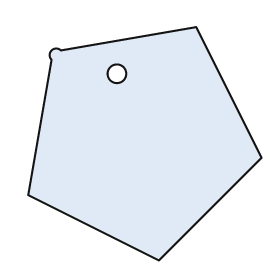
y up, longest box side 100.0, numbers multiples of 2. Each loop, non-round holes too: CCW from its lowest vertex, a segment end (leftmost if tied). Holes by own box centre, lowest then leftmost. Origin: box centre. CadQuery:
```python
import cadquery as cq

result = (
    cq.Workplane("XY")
    .moveTo(6.0, -50.0)
    .lineTo(50.0, -6.0)
    .lineTo(22.0, 50.0)
    .lineTo(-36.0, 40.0)
    .threePointArc((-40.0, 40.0), (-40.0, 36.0))
    .lineTo(-50.0, -22.0)
    .close()
    .moveTo(-12.0, 30.0)
    .circle(4.0)
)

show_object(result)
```